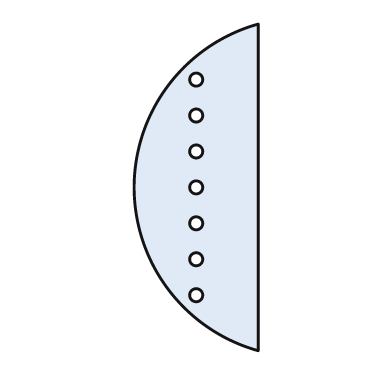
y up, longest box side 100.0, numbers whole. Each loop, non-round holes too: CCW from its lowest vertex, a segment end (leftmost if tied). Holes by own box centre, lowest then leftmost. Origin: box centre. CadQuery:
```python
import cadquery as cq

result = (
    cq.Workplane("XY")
    .moveTo(19.0, -50.0)
    .lineTo(19.0, 50.0)
    .threePointArc((-19.0, 0.0), (19.0, -50.0))
    .close()
    .moveTo(0.0, -33.0)
    .circle(2.0)
    .moveTo(0.0, -22.0)
    .circle(2.0)
    .moveTo(0.0, -11.0)
    .circle(2.0)
    .moveTo(0.0, 0.0)
    .circle(2.0)
    .moveTo(0.0, 11.0)
    .circle(2.0)
    .moveTo(0.0, 22.0)
    .circle(2.0)
    .moveTo(0.0, 33.0)
    .circle(2.0)
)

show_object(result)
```